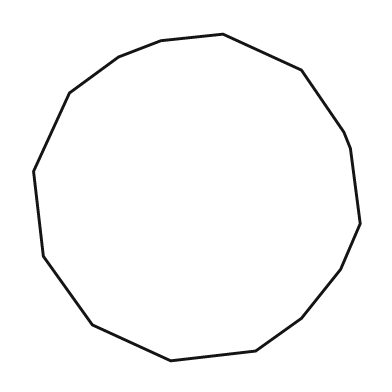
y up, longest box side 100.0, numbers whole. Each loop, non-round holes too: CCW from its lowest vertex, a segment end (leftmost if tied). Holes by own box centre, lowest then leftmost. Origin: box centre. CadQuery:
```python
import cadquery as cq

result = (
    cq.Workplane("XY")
    .moveTo(-8.0, -50.0)
    .lineTo(18.0, -47.0)
    .lineTo(32.0, -37.0)
    .lineTo(44.0, -22.0)
    .lineTo(50.0, -8.0)
    .lineTo(47.0, 15.0)
    .lineTo(45.0, 20.0)
    .lineTo(32.0, 39.0)
    .lineTo(8.0, 50.0)
    .lineTo(-11.0, 48.0)
    .lineTo(-24.0, 43.0)
    .lineTo(-39.0, 32.0)
    .lineTo(-50.0, 8.0)
    .lineTo(-47.0, -18.0)
    .lineTo(-32.0, -39.0)
    .close()
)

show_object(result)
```